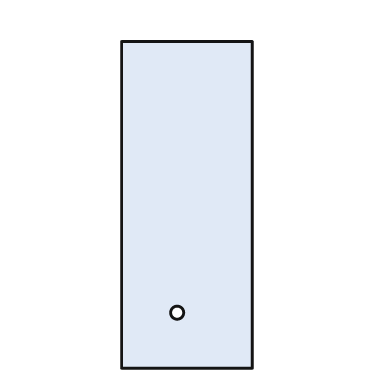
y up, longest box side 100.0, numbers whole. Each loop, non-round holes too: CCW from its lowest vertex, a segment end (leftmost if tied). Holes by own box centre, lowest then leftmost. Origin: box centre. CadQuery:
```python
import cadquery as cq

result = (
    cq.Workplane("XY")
    .moveTo(-20.0, -50.0)
    .lineTo(20.0, -50.0)
    .lineTo(20.0, 50.0)
    .lineTo(-20.0, 50.0)
    .close()
    .moveTo(-3.0, -33.0)
    .circle(2.0)
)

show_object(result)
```